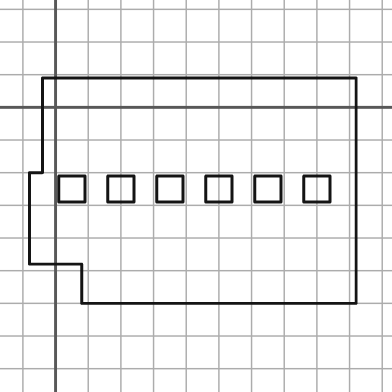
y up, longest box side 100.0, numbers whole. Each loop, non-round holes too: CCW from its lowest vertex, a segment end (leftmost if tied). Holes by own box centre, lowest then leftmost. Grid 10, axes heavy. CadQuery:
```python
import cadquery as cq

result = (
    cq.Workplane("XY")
    .moveTo(8.0, -60.0)
    .lineTo(92.0, -60.0)
    .lineTo(92.0, 9.0)
    .lineTo(-4.0, 9.0)
    .lineTo(-4.0, -20.0)
    .lineTo(-8.0, -20.0)
    .lineTo(-8.0, -48.0)
    .lineTo(8.0, -48.0)
    .close()
    .moveTo(1.0, -29.0)
    .lineTo(9.0, -29.0)
    .lineTo(9.0, -21.0)
    .lineTo(1.0, -21.0)
    .close()
    .moveTo(16.0, -29.0)
    .lineTo(24.0, -29.0)
    .lineTo(24.0, -21.0)
    .lineTo(16.0, -21.0)
    .close()
    .moveTo(31.0, -29.0)
    .lineTo(39.0, -29.0)
    .lineTo(39.0, -21.0)
    .lineTo(31.0, -21.0)
    .close()
    .moveTo(46.0, -29.0)
    .lineTo(54.0, -29.0)
    .lineTo(54.0, -21.0)
    .lineTo(46.0, -21.0)
    .close()
    .moveTo(61.0, -29.0)
    .lineTo(69.0, -29.0)
    .lineTo(69.0, -21.0)
    .lineTo(61.0, -21.0)
    .close()
    .moveTo(76.0, -29.0)
    .lineTo(84.0, -29.0)
    .lineTo(84.0, -21.0)
    .lineTo(76.0, -21.0)
    .close()
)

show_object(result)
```